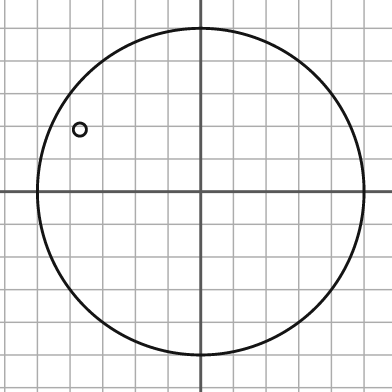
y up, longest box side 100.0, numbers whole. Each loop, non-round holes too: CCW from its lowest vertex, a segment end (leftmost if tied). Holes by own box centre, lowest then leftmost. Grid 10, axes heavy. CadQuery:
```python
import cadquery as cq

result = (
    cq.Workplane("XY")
    .moveTo(0.0, 0.0)
    .circle(50.0)
    .moveTo(-37.0, 19.0)
    .circle(2.0)
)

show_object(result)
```